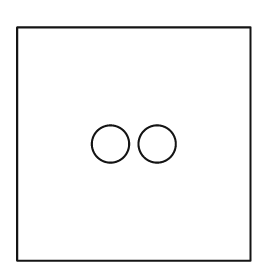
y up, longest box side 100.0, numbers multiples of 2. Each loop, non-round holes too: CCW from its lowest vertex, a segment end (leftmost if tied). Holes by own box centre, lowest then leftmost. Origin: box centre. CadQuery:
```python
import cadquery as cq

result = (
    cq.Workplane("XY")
    .moveTo(-50.0, -50.0)
    .lineTo(50.0, -50.0)
    .lineTo(50.0, 50.0)
    .lineTo(-50.0, 50.0)
    .close()
    .moveTo(-10.0, 0.0)
    .circle(8.0)
    .moveTo(10.0, 0.0)
    .circle(8.0)
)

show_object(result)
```